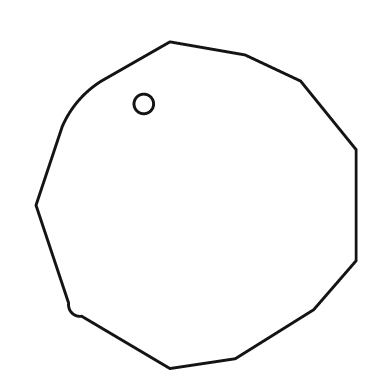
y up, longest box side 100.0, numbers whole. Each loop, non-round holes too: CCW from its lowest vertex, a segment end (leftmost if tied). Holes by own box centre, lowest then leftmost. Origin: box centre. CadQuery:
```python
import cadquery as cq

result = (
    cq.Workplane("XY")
    .moveTo(-8.0, -50.0)
    .lineTo(12.0, -47.0)
    .lineTo(36.0, -32.0)
    .lineTo(49.0, -17.0)
    .lineTo(49.0, 17.0)
    .lineTo(32.0, 38.0)
    .lineTo(15.0, 46.0)
    .lineTo(-8.0, 50.0)
    .lineTo(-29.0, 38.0)
    .threePointArc((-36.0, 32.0), (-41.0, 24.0))
    .lineTo(-49.0, 0.0)
    .lineTo(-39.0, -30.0)
    .threePointArc((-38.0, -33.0), (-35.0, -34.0))
    .close()
    .moveTo(-16.0, 31.0)
    .circle(3.0)
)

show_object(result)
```